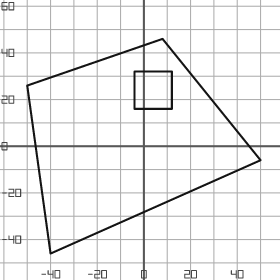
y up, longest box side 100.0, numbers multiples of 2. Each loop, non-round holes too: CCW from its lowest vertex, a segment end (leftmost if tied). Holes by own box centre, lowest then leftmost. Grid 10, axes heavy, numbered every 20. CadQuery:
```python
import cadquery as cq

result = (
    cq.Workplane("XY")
    .moveTo(-40.0, -46.0)
    .lineTo(50.0, -6.0)
    .lineTo(8.0, 46.0)
    .lineTo(-50.0, 26.0)
    .close()
    .moveTo(-4.0, 16.0)
    .lineTo(12.0, 16.0)
    .lineTo(12.0, 32.0)
    .lineTo(-4.0, 32.0)
    .close()
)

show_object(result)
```